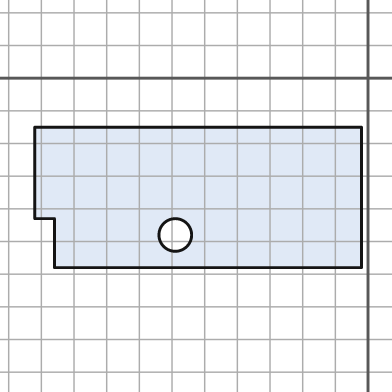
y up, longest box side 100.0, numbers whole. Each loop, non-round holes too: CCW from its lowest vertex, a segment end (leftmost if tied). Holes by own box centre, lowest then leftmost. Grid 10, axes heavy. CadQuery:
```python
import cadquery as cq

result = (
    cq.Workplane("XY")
    .moveTo(-96.0, -58.0)
    .lineTo(-2.0, -58.0)
    .lineTo(-2.0, -15.0)
    .lineTo(-102.0, -15.0)
    .lineTo(-102.0, -43.0)
    .lineTo(-96.0, -43.0)
    .close()
    .moveTo(-59.0, -48.0)
    .circle(5.0)
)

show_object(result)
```